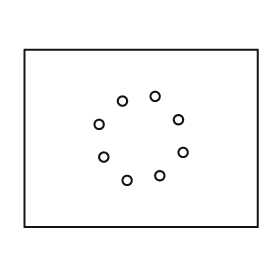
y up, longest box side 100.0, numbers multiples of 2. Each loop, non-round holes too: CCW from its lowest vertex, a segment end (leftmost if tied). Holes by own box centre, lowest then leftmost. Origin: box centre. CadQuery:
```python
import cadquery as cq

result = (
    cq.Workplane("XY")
    .moveTo(-50.0, -38.0)
    .lineTo(50.0, -38.0)
    .lineTo(50.0, 38.0)
    .lineTo(-50.0, 38.0)
    .close()
    .moveTo(-6.0, -18.0)
    .circle(2.0)
    .moveTo(8.0, -16.0)
    .circle(2.0)
    .moveTo(-16.0, -8.0)
    .circle(2.0)
    .moveTo(18.0, -6.0)
    .circle(2.0)
    .moveTo(-18.0, 6.0)
    .circle(2.0)
    .moveTo(16.0, 8.0)
    .circle(2.0)
    .moveTo(-8.0, 16.0)
    .circle(2.0)
    .moveTo(6.0, 18.0)
    .circle(2.0)
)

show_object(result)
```